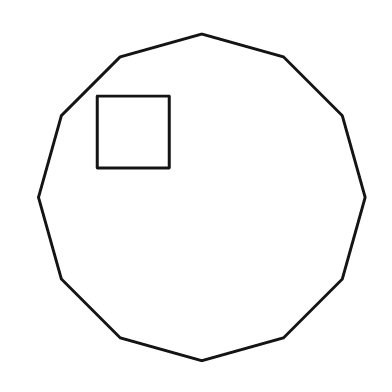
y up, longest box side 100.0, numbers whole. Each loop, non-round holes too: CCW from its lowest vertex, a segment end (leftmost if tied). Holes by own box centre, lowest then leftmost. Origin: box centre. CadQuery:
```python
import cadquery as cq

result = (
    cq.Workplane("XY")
    .moveTo(0.0, -50.0)
    .lineTo(25.0, -43.0)
    .lineTo(43.0, -25.0)
    .lineTo(50.0, 0.0)
    .lineTo(43.0, 25.0)
    .lineTo(25.0, 43.0)
    .lineTo(0.0, 50.0)
    .lineTo(-25.0, 43.0)
    .lineTo(-43.0, 25.0)
    .lineTo(-50.0, 0.0)
    .lineTo(-43.0, -25.0)
    .lineTo(-25.0, -43.0)
    .close()
    .moveTo(-32.0, 9.0)
    .lineTo(-10.0, 9.0)
    .lineTo(-10.0, 31.0)
    .lineTo(-32.0, 31.0)
    .close()
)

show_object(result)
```